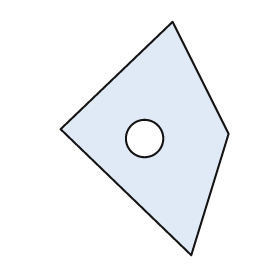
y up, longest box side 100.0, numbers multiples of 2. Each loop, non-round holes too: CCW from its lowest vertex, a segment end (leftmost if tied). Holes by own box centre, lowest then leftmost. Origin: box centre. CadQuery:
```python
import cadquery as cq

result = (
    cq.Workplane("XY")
    .moveTo(20.0, -50.0)
    .lineTo(36.0, 2.0)
    .lineTo(12.0, 50.0)
    .lineTo(-36.0, 4.0)
    .close()
    .moveTo(0.0, 0.0)
    .circle(8.0)
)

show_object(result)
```